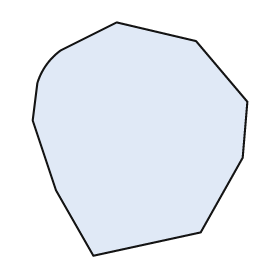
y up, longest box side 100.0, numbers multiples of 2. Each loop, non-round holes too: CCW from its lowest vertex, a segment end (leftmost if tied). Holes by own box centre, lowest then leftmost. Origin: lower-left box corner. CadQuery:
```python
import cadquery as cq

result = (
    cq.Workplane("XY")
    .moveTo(26.0, 0.0)
    .lineTo(72.0, 10.0)
    .lineTo(90.0, 42.0)
    .lineTo(92.0, 66.0)
    .lineTo(70.0, 92.0)
    .lineTo(36.0, 100.0)
    .lineTo(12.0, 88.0)
    .threePointArc((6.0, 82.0), (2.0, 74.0))
    .lineTo(0.0, 58.0)
    .lineTo(10.0, 28.0)
    .close()
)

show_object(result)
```